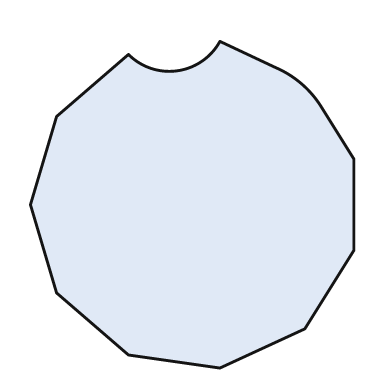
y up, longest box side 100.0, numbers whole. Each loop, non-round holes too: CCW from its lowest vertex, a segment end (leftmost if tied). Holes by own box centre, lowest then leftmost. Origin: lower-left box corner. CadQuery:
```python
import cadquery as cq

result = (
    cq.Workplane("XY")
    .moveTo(58.0, 0.0)
    .lineTo(84.0, 12.0)
    .lineTo(99.0, 36.0)
    .lineTo(99.0, 64.0)
    .lineTo(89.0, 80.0)
    .threePointArc((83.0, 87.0), (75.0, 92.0))
    .lineTo(58.0, 100.0)
    .threePointArc((45.0, 91.0), (30.0, 96.0))
    .lineTo(8.0, 77.0)
    .lineTo(0.0, 50.0)
    .lineTo(8.0, 23.0)
    .lineTo(30.0, 4.0)
    .close()
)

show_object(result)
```